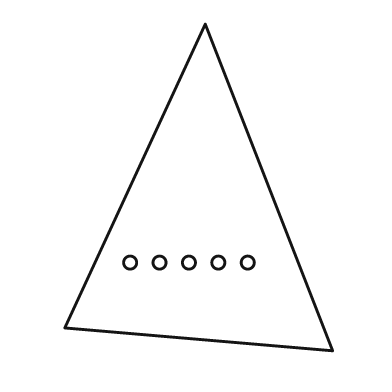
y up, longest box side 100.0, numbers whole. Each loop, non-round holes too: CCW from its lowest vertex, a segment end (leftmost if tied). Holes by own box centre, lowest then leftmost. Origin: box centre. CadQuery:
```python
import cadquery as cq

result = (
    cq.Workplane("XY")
    .moveTo(41.0, -50.0)
    .lineTo(2.0, 50.0)
    .lineTo(-41.0, -43.0)
    .close()
    .moveTo(-21.0, -23.0)
    .circle(2.0)
    .moveTo(-12.0, -23.0)
    .circle(2.0)
    .moveTo(-3.0, -23.0)
    .circle(2.0)
    .moveTo(6.0, -23.0)
    .circle(2.0)
    .moveTo(15.0, -23.0)
    .circle(2.0)
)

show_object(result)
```